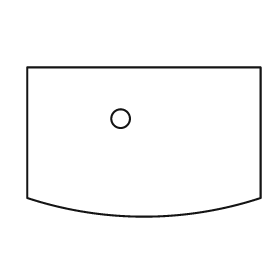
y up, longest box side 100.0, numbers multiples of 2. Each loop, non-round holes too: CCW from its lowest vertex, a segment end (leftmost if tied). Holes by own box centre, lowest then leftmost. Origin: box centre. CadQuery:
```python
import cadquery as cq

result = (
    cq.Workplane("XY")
    .moveTo(-50.0, -24.0)
    .threePointArc((0.0, -32.0), (50.0, -24.0))
    .lineTo(50.0, 32.0)
    .lineTo(-50.0, 32.0)
    .close()
    .moveTo(-10.0, 10.0)
    .circle(4.0)
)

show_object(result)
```